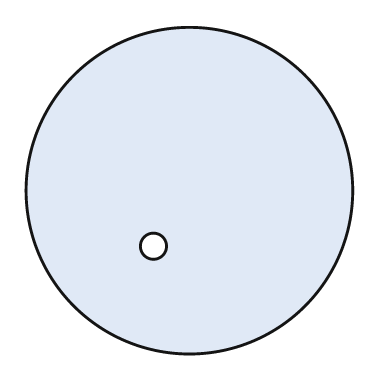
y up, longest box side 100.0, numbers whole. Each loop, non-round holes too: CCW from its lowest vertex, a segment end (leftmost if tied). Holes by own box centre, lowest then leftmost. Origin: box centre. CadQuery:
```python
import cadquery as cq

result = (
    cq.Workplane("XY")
    .moveTo(0.0, 0.0)
    .circle(50.0)
    .moveTo(-11.0, -17.0)
    .circle(4.0)
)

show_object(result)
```